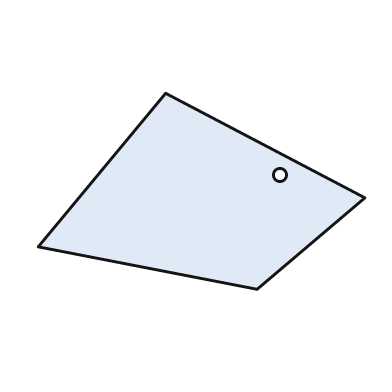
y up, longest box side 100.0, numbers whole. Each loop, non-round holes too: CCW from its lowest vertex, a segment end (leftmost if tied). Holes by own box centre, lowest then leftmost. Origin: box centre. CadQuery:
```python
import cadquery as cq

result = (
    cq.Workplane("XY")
    .moveTo(17.0, -30.0)
    .lineTo(50.0, -2.0)
    .lineTo(-11.0, 30.0)
    .lineTo(-50.0, -17.0)
    .close()
    .moveTo(24.0, 5.0)
    .circle(2.0)
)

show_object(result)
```